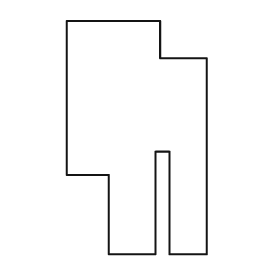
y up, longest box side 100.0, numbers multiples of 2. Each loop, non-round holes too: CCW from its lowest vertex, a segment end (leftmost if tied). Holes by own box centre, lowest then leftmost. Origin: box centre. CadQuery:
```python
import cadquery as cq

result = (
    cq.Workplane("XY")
    .moveTo(-12.0, -50.0)
    .lineTo(8.0, -50.0)
    .lineTo(8.0, -6.0)
    .lineTo(14.0, -6.0)
    .lineTo(14.0, -50.0)
    .lineTo(30.0, -50.0)
    .lineTo(30.0, 34.0)
    .lineTo(10.0, 34.0)
    .lineTo(10.0, 50.0)
    .lineTo(-30.0, 50.0)
    .lineTo(-30.0, -16.0)
    .lineTo(-12.0, -16.0)
    .close()
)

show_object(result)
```